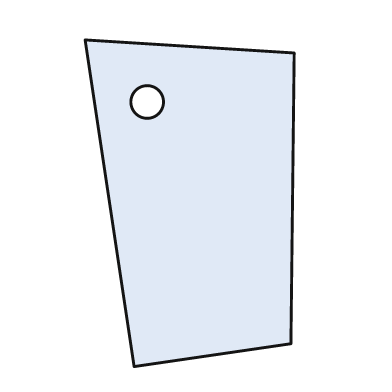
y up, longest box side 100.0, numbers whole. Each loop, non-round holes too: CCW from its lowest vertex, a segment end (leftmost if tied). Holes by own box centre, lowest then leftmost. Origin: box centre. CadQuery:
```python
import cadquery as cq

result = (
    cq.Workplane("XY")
    .moveTo(-17.0, -50.0)
    .lineTo(31.0, -43.0)
    .lineTo(32.0, 46.0)
    .lineTo(-32.0, 50.0)
    .close()
    .moveTo(-13.0, 31.0)
    .circle(5.0)
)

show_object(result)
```